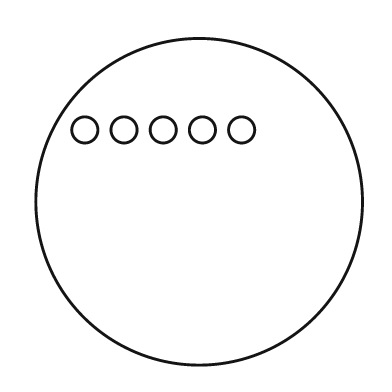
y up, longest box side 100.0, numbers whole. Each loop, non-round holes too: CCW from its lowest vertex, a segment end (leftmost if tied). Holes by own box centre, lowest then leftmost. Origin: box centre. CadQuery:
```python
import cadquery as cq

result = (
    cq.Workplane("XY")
    .moveTo(0.0, 0.0)
    .circle(50.0)
    .moveTo(-35.0, 22.0)
    .circle(4.0)
    .moveTo(-23.0, 22.0)
    .circle(4.0)
    .moveTo(-11.0, 22.0)
    .circle(4.0)
    .moveTo(1.0, 22.0)
    .circle(4.0)
    .moveTo(13.0, 22.0)
    .circle(4.0)
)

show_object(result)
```